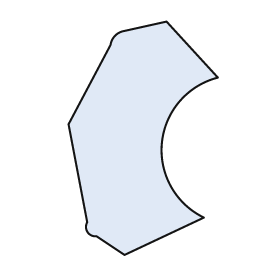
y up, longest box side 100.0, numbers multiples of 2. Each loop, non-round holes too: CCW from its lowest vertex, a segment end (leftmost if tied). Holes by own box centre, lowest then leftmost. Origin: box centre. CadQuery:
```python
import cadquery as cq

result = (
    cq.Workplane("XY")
    .moveTo(-8.0, -50.0)
    .lineTo(26.0, -34.0)
    .threePointArc((8.0, -2.0), (32.0, 26.0))
    .lineTo(10.0, 50.0)
    .lineTo(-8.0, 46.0)
    .threePointArc((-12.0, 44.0), (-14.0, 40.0))
    .lineTo(-32.0, 6.0)
    .lineTo(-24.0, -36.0)
    .threePointArc((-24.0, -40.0), (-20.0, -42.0))
    .close()
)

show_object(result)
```